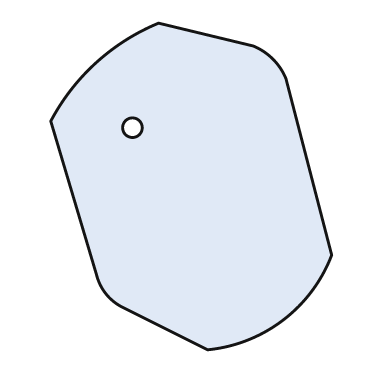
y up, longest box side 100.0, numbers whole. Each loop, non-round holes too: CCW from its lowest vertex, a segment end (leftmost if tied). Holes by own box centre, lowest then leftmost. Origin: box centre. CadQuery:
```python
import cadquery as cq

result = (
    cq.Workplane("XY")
    .moveTo(5.0, -50.0)
    .threePointArc((28.0, -41.0), (43.0, -21.0))
    .lineTo(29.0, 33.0)
    .threePointArc((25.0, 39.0), (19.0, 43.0))
    .lineTo(-10.0, 50.0)
    .threePointArc((-29.0, 38.0), (-43.0, 20.0))
    .lineTo(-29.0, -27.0)
    .threePointArc((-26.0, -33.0), (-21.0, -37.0))
    .close()
    .moveTo(-18.0, 18.0)
    .circle(3.0)
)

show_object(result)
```